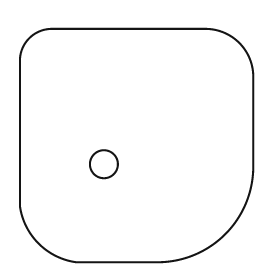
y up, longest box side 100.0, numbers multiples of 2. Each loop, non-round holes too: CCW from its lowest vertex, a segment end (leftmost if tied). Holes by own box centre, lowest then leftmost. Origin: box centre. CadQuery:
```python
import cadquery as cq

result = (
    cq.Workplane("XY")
    .moveTo(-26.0, -50.0)
    .lineTo(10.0, -50.0)
    .threePointArc((38.0, -38.0), (50.0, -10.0))
    .lineTo(50.0, 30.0)
    .threePointArc((44.0, 44.0), (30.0, 50.0))
    .lineTo(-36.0, 50.0)
    .threePointArc((-46.0, 46.0), (-50.0, 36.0))
    .lineTo(-50.0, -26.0)
    .threePointArc((-42.0, -42.0), (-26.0, -50.0))
    .close()
    .moveTo(-14.0, -8.0)
    .circle(6.0)
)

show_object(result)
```